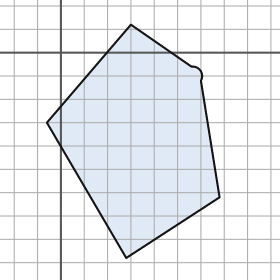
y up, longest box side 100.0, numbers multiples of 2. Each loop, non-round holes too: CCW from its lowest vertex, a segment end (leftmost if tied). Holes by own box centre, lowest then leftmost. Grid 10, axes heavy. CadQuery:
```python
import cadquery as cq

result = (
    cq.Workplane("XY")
    .moveTo(28.0, -88.0)
    .lineTo(68.0, -62.0)
    .lineTo(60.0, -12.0)
    .threePointArc((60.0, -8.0), (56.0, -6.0))
    .lineTo(30.0, 12.0)
    .lineTo(-6.0, -30.0)
    .close()
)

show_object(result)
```